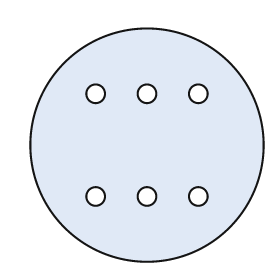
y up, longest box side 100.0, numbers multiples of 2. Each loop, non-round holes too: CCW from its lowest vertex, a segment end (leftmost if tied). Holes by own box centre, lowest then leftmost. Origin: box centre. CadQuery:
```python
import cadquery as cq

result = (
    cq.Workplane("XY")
    .moveTo(0.0, 0.0)
    .circle(50.0)
    .moveTo(-22.0, -22.0)
    .circle(4.0)
    .moveTo(0.0, -22.0)
    .circle(4.0)
    .moveTo(22.0, -22.0)
    .circle(4.0)
    .moveTo(-22.0, 22.0)
    .circle(4.0)
    .moveTo(0.0, 22.0)
    .circle(4.0)
    .moveTo(22.0, 22.0)
    .circle(4.0)
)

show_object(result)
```